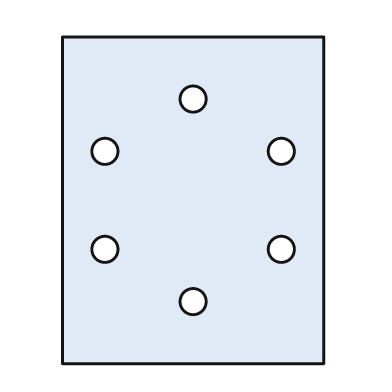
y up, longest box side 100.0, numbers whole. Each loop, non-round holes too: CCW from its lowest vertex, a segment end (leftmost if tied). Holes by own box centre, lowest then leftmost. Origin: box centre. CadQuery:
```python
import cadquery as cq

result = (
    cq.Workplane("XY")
    .moveTo(-40.0, -50.0)
    .lineTo(40.0, -50.0)
    .lineTo(40.0, 50.0)
    .lineTo(-40.0, 50.0)
    .close()
    .moveTo(0.0, -31.0)
    .circle(4.0)
    .moveTo(-27.0, -15.0)
    .circle(4.0)
    .moveTo(27.0, -15.0)
    .circle(4.0)
    .moveTo(-27.0, 15.0)
    .circle(4.0)
    .moveTo(27.0, 15.0)
    .circle(4.0)
    .moveTo(0.0, 31.0)
    .circle(4.0)
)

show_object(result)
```